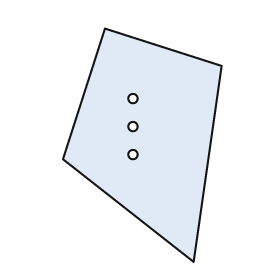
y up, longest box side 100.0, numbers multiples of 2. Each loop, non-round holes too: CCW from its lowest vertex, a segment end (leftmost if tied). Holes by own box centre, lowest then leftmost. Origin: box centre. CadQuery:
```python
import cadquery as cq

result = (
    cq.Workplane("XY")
    .moveTo(22.0, -50.0)
    .lineTo(34.0, 34.0)
    .lineTo(-16.0, 50.0)
    .lineTo(-34.0, -6.0)
    .close()
    .moveTo(-4.0, -4.0)
    .circle(2.0)
    .moveTo(-4.0, 8.0)
    .circle(2.0)
    .moveTo(-4.0, 20.0)
    .circle(2.0)
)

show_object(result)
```